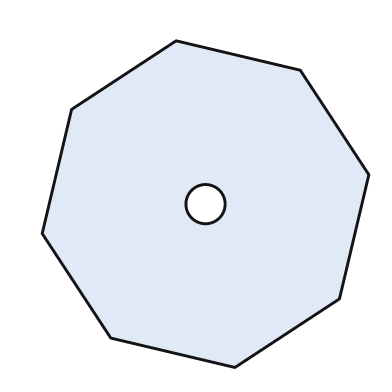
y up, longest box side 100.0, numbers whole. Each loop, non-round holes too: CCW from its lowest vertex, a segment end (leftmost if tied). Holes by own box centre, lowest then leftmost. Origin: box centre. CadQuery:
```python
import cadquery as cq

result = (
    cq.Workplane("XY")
    .moveTo(9.0, -50.0)
    .lineTo(41.0, -29.0)
    .lineTo(50.0, 9.0)
    .lineTo(29.0, 41.0)
    .lineTo(-9.0, 50.0)
    .lineTo(-41.0, 29.0)
    .lineTo(-50.0, -9.0)
    .lineTo(-29.0, -41.0)
    .close()
    .moveTo(0.0, 0.0)
    .circle(6.0)
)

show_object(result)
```